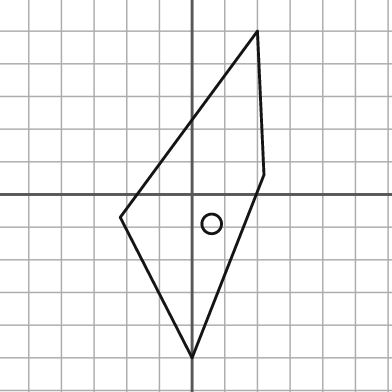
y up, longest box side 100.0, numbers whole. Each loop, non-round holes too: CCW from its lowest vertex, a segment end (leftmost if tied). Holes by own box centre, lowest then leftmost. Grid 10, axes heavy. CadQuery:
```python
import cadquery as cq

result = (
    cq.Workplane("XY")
    .moveTo(0.0, -50.0)
    .lineTo(22.0, 6.0)
    .lineTo(20.0, 50.0)
    .lineTo(-22.0, -7.0)
    .close()
    .moveTo(6.0, -9.0)
    .circle(3.0)
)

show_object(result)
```